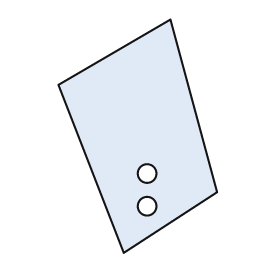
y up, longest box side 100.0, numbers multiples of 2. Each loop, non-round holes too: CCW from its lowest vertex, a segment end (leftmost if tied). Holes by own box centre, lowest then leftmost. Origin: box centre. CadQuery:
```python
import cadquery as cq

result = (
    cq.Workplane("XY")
    .moveTo(-6.0, -50.0)
    .lineTo(34.0, -24.0)
    .lineTo(14.0, 50.0)
    .lineTo(-34.0, 22.0)
    .close()
    .moveTo(4.0, -30.0)
    .circle(4.0)
    .moveTo(4.0, -16.0)
    .circle(4.0)
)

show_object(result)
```